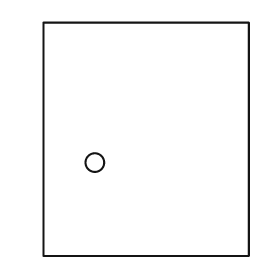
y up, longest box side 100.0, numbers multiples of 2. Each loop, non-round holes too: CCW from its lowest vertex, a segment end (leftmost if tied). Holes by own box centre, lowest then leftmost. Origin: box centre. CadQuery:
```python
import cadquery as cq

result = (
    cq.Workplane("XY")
    .moveTo(-44.0, -50.0)
    .lineTo(44.0, -50.0)
    .lineTo(44.0, 50.0)
    .lineTo(-44.0, 50.0)
    .close()
    .moveTo(-22.0, -10.0)
    .circle(4.0)
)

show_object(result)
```